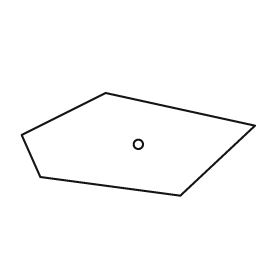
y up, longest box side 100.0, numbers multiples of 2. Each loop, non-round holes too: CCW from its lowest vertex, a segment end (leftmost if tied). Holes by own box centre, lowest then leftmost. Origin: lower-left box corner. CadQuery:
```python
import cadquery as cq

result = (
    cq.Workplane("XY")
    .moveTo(68.0, 0.0)
    .lineTo(100.0, 30.0)
    .lineTo(36.0, 44.0)
    .lineTo(0.0, 26.0)
    .lineTo(8.0, 8.0)
    .close()
    .moveTo(50.0, 22.0)
    .circle(2.0)
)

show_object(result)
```